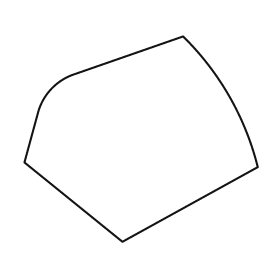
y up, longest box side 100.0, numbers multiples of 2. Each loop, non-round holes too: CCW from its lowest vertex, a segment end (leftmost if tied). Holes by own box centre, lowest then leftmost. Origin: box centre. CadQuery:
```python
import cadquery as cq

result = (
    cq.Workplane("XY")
    .moveTo(-8.0, -44.0)
    .lineTo(50.0, -12.0)
    .threePointArc((38.0, 18.0), (18.0, 44.0))
    .lineTo(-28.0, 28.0)
    .threePointArc((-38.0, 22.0), (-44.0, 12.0))
    .lineTo(-50.0, -10.0)
    .close()
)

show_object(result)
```